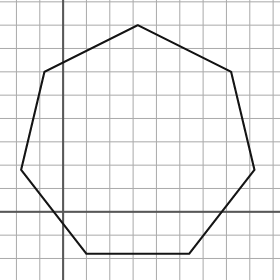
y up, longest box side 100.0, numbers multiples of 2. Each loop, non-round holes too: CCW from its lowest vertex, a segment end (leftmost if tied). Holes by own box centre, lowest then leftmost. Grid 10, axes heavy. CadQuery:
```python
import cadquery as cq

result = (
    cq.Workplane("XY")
    .moveTo(10.0, -18.0)
    .lineTo(54.0, -18.0)
    .lineTo(82.0, 18.0)
    .lineTo(72.0, 60.0)
    .lineTo(32.0, 80.0)
    .lineTo(-8.0, 60.0)
    .lineTo(-18.0, 18.0)
    .close()
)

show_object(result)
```